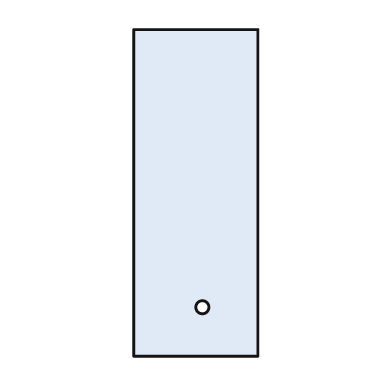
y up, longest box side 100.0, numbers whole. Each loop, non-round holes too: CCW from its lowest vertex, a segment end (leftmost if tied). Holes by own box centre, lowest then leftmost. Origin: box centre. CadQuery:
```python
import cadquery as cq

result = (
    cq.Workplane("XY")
    .moveTo(-19.0, -50.0)
    .lineTo(19.0, -50.0)
    .lineTo(19.0, 50.0)
    .lineTo(-19.0, 50.0)
    .close()
    .moveTo(2.0, -35.0)
    .circle(2.0)
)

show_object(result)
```